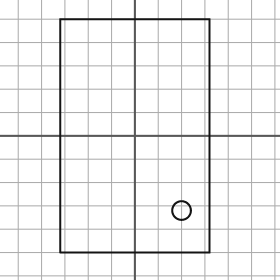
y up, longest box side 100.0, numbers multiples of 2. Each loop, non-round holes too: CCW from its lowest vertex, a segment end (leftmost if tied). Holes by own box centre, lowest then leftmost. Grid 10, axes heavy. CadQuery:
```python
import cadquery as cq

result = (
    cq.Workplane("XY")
    .moveTo(-32.0, -50.0)
    .lineTo(32.0, -50.0)
    .lineTo(32.0, 50.0)
    .lineTo(-32.0, 50.0)
    .close()
    .moveTo(20.0, -32.0)
    .circle(4.0)
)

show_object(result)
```